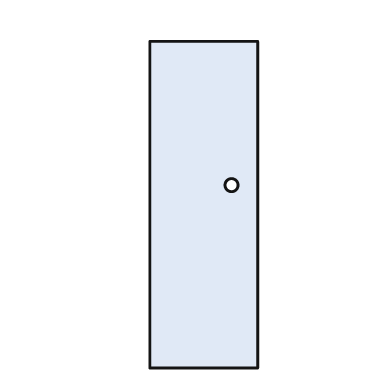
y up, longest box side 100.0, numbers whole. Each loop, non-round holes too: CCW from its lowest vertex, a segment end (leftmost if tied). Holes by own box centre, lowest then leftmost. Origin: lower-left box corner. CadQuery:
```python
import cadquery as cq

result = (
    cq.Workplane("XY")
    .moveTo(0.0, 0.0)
    .lineTo(33.0, 0.0)
    .lineTo(33.0, 100.0)
    .lineTo(0.0, 100.0)
    .close()
    .moveTo(25.0, 56.0)
    .circle(2.0)
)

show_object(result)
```